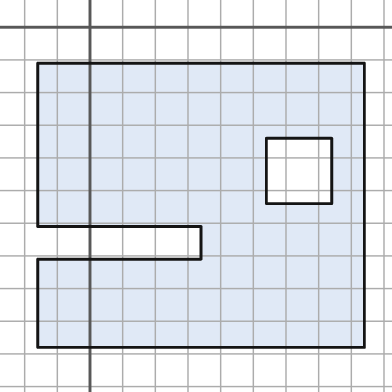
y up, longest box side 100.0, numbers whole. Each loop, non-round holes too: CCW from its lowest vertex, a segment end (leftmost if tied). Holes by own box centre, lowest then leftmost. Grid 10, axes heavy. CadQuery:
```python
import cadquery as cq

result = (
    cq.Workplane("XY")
    .moveTo(-16.0, -98.0)
    .lineTo(84.0, -98.0)
    .lineTo(84.0, -11.0)
    .lineTo(-16.0, -11.0)
    .lineTo(-16.0, -61.0)
    .lineTo(34.0, -61.0)
    .lineTo(34.0, -71.0)
    .lineTo(-16.0, -71.0)
    .close()
    .moveTo(54.0, -54.0)
    .lineTo(74.0, -54.0)
    .lineTo(74.0, -34.0)
    .lineTo(54.0, -34.0)
    .close()
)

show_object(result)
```